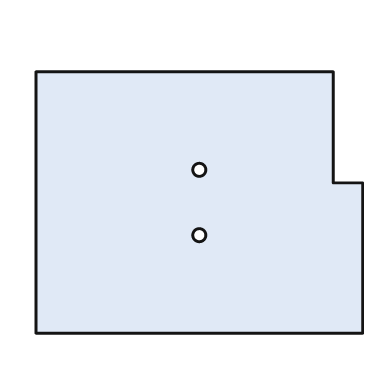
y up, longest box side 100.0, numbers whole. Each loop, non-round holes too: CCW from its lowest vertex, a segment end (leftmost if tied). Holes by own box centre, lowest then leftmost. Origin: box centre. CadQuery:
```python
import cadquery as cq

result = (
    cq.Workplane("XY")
    .moveTo(-50.0, -40.0)
    .lineTo(50.0, -40.0)
    .lineTo(50.0, 6.0)
    .lineTo(41.0, 6.0)
    .lineTo(41.0, 40.0)
    .lineTo(-50.0, 40.0)
    .close()
    .moveTo(0.0, -10.0)
    .circle(2.0)
    .moveTo(0.0, 10.0)
    .circle(2.0)
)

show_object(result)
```